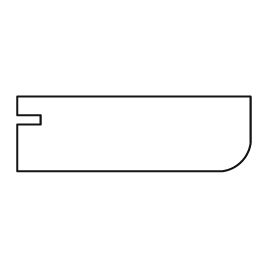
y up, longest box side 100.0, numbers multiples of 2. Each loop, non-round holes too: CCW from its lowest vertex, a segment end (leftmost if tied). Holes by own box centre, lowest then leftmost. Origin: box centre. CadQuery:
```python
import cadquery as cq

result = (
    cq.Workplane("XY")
    .moveTo(-50.0, -16.0)
    .lineTo(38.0, -16.0)
    .threePointArc((46.0, -12.0), (50.0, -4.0))
    .lineTo(50.0, 16.0)
    .lineTo(-50.0, 16.0)
    .lineTo(-50.0, 8.0)
    .lineTo(-40.0, 8.0)
    .lineTo(-40.0, 4.0)
    .lineTo(-50.0, 4.0)
    .close()
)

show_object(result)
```